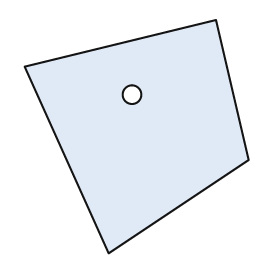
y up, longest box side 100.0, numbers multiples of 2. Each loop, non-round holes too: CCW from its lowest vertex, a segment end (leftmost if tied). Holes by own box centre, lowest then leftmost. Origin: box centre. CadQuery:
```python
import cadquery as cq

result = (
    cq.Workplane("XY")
    .moveTo(-12.0, -50.0)
    .lineTo(48.0, -10.0)
    .lineTo(34.0, 50.0)
    .lineTo(-48.0, 30.0)
    .close()
    .moveTo(-2.0, 18.0)
    .circle(4.0)
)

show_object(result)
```